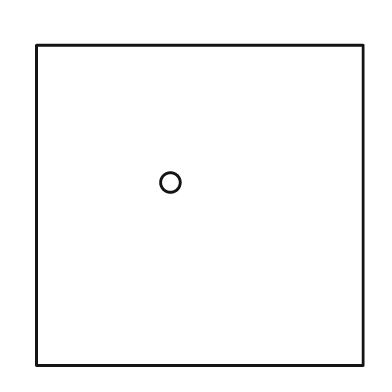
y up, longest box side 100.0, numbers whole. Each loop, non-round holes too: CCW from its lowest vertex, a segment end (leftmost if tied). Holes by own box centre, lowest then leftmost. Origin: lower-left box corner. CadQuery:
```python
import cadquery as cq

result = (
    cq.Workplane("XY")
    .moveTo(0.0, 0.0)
    .lineTo(100.0, 0.0)
    .lineTo(100.0, 98.0)
    .lineTo(0.0, 98.0)
    .close()
    .moveTo(41.0, 56.0)
    .circle(3.0)
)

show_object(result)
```